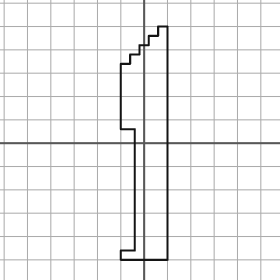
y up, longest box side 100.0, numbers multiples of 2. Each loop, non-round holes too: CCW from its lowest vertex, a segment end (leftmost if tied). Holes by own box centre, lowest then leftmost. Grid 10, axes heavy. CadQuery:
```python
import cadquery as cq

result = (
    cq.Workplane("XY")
    .moveTo(-10.0, -50.0)
    .lineTo(10.0, -50.0)
    .lineTo(10.0, 50.0)
    .lineTo(6.0, 50.0)
    .lineTo(6.0, 46.0)
    .lineTo(2.0, 46.0)
    .lineTo(2.0, 42.0)
    .lineTo(-2.0, 42.0)
    .lineTo(-2.0, 38.0)
    .lineTo(-6.0, 38.0)
    .lineTo(-6.0, 34.0)
    .lineTo(-10.0, 34.0)
    .lineTo(-10.0, 6.0)
    .lineTo(-4.0, 6.0)
    .lineTo(-4.0, -46.0)
    .lineTo(-10.0, -46.0)
    .close()
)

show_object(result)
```